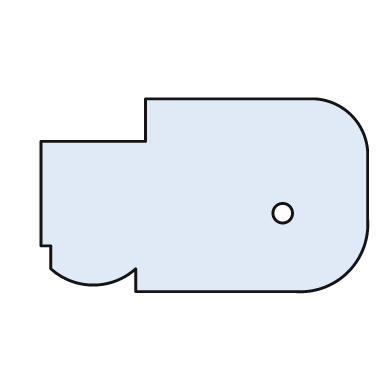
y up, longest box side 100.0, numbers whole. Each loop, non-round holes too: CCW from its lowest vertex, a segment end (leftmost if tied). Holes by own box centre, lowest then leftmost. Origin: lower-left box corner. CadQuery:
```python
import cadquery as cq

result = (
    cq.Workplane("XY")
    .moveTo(29.0, 0.0)
    .lineTo(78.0, 0.0)
    .threePointArc((94.0, 6.0), (100.0, 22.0))
    .lineTo(100.0, 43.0)
    .threePointArc((95.0, 54.0), (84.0, 59.0))
    .lineTo(32.0, 59.0)
    .lineTo(32.0, 46.0)
    .lineTo(0.0, 46.0)
    .lineTo(0.0, 14.0)
    .lineTo(3.0, 14.0)
    .lineTo(3.0, 7.0)
    .threePointArc((16.0, 2.0), (29.0, 7.0))
    .close()
    .moveTo(74.0, 24.0)
    .circle(3.0)
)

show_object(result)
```